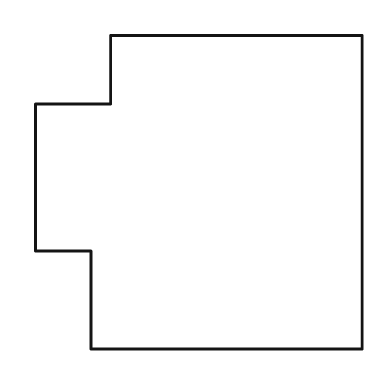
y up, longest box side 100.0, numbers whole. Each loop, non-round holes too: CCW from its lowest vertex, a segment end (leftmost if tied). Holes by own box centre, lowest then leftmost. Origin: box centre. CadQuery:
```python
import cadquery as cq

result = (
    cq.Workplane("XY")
    .moveTo(-33.0, -48.0)
    .lineTo(50.0, -48.0)
    .lineTo(50.0, 48.0)
    .lineTo(-27.0, 48.0)
    .lineTo(-27.0, 27.0)
    .lineTo(-50.0, 27.0)
    .lineTo(-50.0, -18.0)
    .lineTo(-33.0, -18.0)
    .close()
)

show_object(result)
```